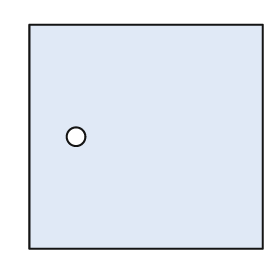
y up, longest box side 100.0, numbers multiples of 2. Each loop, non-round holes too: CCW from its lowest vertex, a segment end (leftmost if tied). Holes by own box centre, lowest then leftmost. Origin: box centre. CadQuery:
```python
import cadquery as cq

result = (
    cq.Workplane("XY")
    .moveTo(-50.0, -48.0)
    .lineTo(50.0, -48.0)
    .lineTo(50.0, 48.0)
    .lineTo(-50.0, 48.0)
    .close()
    .moveTo(-30.0, 0.0)
    .circle(4.0)
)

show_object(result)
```